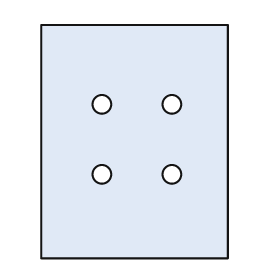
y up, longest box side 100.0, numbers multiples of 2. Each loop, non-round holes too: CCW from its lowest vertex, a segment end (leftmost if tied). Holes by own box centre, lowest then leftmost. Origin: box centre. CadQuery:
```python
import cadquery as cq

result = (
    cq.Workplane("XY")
    .moveTo(-40.0, -50.0)
    .lineTo(40.0, -50.0)
    .lineTo(40.0, 50.0)
    .lineTo(-40.0, 50.0)
    .close()
    .moveTo(-14.0, -14.0)
    .circle(4.0)
    .moveTo(16.0, -14.0)
    .circle(4.0)
    .moveTo(-14.0, 16.0)
    .circle(4.0)
    .moveTo(16.0, 16.0)
    .circle(4.0)
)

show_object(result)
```